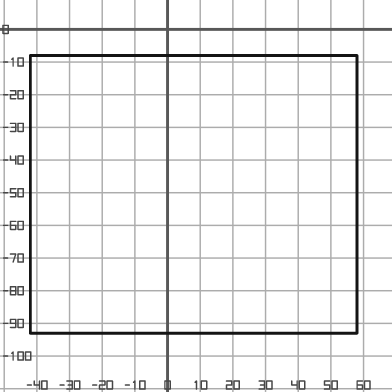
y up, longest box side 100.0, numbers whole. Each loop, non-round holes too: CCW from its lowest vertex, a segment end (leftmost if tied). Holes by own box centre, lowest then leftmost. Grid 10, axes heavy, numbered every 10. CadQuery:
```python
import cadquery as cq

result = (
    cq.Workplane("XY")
    .moveTo(-42.0, -93.0)
    .lineTo(58.0, -93.0)
    .lineTo(58.0, -8.0)
    .lineTo(-42.0, -8.0)
    .close()
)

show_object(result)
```